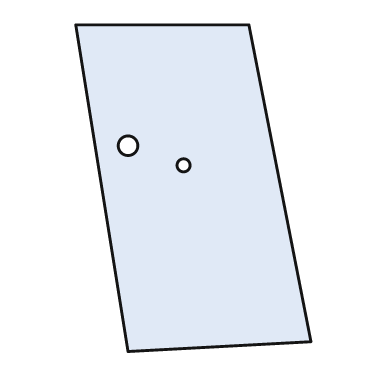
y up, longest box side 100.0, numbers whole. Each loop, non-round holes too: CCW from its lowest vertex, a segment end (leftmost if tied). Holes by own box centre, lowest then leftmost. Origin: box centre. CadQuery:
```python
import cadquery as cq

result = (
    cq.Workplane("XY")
    .moveTo(-20.0, -50.0)
    .lineTo(36.0, -47.0)
    .lineTo(17.0, 50.0)
    .lineTo(-36.0, 50.0)
    .close()
    .moveTo(-3.0, 7.0)
    .circle(2.0)
    .moveTo(-20.0, 13.0)
    .circle(3.0)
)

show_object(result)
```